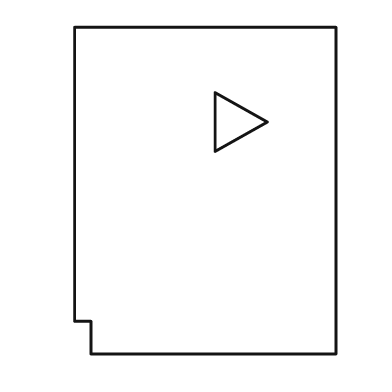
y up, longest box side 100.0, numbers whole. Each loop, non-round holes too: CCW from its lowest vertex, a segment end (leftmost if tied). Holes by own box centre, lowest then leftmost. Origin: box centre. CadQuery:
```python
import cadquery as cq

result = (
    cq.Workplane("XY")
    .moveTo(-35.0, -50.0)
    .lineTo(40.0, -50.0)
    .lineTo(40.0, 50.0)
    .lineTo(-40.0, 50.0)
    .lineTo(-40.0, -40.0)
    .lineTo(-35.0, -40.0)
    .close()
    .moveTo(3.0, 12.0)
    .lineTo(19.0, 21.0)
    .lineTo(3.0, 30.0)
    .close()
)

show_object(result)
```